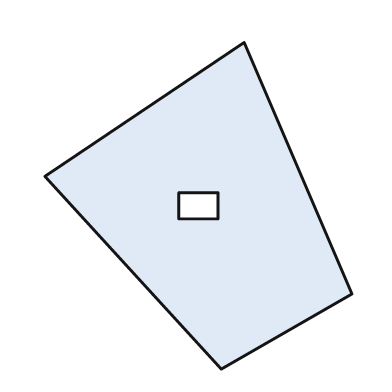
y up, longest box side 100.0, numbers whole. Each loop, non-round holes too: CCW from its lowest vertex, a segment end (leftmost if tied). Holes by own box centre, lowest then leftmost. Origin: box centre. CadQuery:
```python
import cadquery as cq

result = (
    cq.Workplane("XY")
    .moveTo(7.0, -50.0)
    .lineTo(47.0, -27.0)
    .lineTo(14.0, 50.0)
    .lineTo(-47.0, 9.0)
    .close()
    .moveTo(-6.0, -4.0)
    .lineTo(6.0, -4.0)
    .lineTo(6.0, 4.0)
    .lineTo(-6.0, 4.0)
    .close()
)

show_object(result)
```